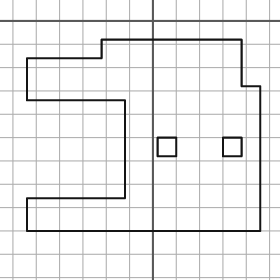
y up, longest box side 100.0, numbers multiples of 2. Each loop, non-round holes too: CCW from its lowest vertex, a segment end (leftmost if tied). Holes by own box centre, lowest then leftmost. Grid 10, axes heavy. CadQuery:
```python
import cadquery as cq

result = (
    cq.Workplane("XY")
    .moveTo(-54.0, -90.0)
    .lineTo(46.0, -90.0)
    .lineTo(46.0, -28.0)
    .lineTo(38.0, -28.0)
    .lineTo(38.0, -8.0)
    .lineTo(-22.0, -8.0)
    .lineTo(-22.0, -16.0)
    .lineTo(-54.0, -16.0)
    .lineTo(-54.0, -34.0)
    .lineTo(-12.0, -34.0)
    .lineTo(-12.0, -76.0)
    .lineTo(-54.0, -76.0)
    .close()
    .moveTo(2.0, -58.0)
    .lineTo(10.0, -58.0)
    .lineTo(10.0, -50.0)
    .lineTo(2.0, -50.0)
    .close()
    .moveTo(30.0, -58.0)
    .lineTo(38.0, -58.0)
    .lineTo(38.0, -50.0)
    .lineTo(30.0, -50.0)
    .close()
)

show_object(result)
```